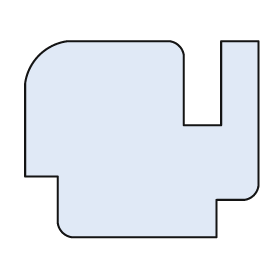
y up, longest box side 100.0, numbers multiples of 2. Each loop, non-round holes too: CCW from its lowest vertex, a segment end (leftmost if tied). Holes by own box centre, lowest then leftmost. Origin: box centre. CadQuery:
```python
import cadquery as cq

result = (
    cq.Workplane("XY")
    .moveTo(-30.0, -42.0)
    .lineTo(32.0, -42.0)
    .lineTo(32.0, -26.0)
    .lineTo(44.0, -26.0)
    .threePointArc((48.0, -24.0), (50.0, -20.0))
    .lineTo(50.0, 42.0)
    .lineTo(34.0, 42.0)
    .lineTo(34.0, 6.0)
    .lineTo(18.0, 6.0)
    .lineTo(18.0, 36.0)
    .threePointArc((16.0, 40.0), (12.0, 42.0))
    .lineTo(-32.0, 42.0)
    .threePointArc((-44.0, 36.0), (-50.0, 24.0))
    .lineTo(-50.0, -16.0)
    .lineTo(-36.0, -16.0)
    .lineTo(-36.0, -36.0)
    .threePointArc((-34.0, -40.0), (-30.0, -42.0))
    .close()
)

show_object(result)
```